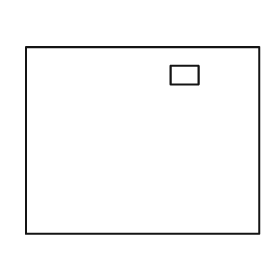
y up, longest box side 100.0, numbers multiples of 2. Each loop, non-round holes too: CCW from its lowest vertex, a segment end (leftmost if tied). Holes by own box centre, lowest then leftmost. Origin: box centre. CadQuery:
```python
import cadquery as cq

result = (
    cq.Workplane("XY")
    .moveTo(-50.0, -40.0)
    .lineTo(50.0, -40.0)
    .lineTo(50.0, 40.0)
    .lineTo(-50.0, 40.0)
    .close()
    .moveTo(12.0, 24.0)
    .lineTo(24.0, 24.0)
    .lineTo(24.0, 32.0)
    .lineTo(12.0, 32.0)
    .close()
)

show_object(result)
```